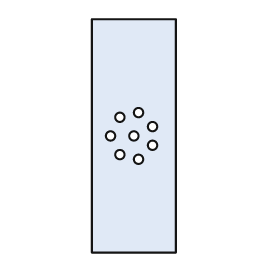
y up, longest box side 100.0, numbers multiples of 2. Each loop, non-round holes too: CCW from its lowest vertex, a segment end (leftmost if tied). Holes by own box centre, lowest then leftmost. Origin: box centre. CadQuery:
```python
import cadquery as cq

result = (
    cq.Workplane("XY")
    .moveTo(-18.0, -50.0)
    .lineTo(18.0, -50.0)
    .lineTo(18.0, 50.0)
    .lineTo(-18.0, 50.0)
    .close()
    .moveTo(2.0, -10.0)
    .circle(2.0)
    .moveTo(-6.0, -8.0)
    .circle(2.0)
    .moveTo(8.0, -4.0)
    .circle(2.0)
    .moveTo(-10.0, 0.0)
    .circle(2.0)
    .moveTo(0.0, 0.0)
    .circle(2.0)
    .moveTo(8.0, 4.0)
    .circle(2.0)
    .moveTo(-6.0, 8.0)
    .circle(2.0)
    .moveTo(2.0, 10.0)
    .circle(2.0)
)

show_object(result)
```